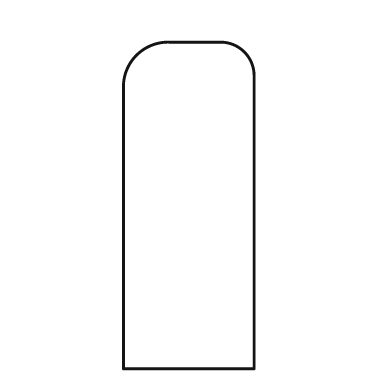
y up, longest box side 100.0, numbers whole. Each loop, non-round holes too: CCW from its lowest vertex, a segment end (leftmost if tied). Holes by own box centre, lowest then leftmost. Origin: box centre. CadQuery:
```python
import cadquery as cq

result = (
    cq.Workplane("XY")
    .moveTo(-20.0, -50.0)
    .lineTo(20.0, -50.0)
    .lineTo(20.0, 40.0)
    .threePointArc((17.0, 47.0), (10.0, 50.0))
    .lineTo(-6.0, 50.0)
    .threePointArc((-16.0, 46.0), (-20.0, 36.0))
    .close()
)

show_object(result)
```